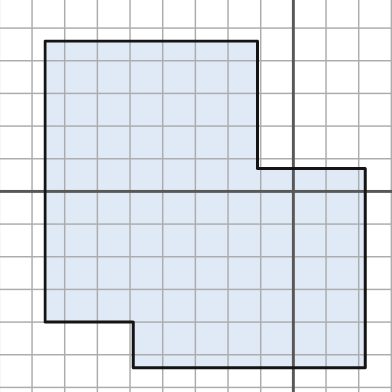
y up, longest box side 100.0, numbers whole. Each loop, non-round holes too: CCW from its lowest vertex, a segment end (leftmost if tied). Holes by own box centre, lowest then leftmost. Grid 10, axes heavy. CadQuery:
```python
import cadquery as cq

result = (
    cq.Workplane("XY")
    .moveTo(-49.0, -54.0)
    .lineTo(22.0, -54.0)
    .lineTo(22.0, 7.0)
    .lineTo(-11.0, 7.0)
    .lineTo(-11.0, 46.0)
    .lineTo(-76.0, 46.0)
    .lineTo(-76.0, -40.0)
    .lineTo(-49.0, -40.0)
    .close()
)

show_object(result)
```